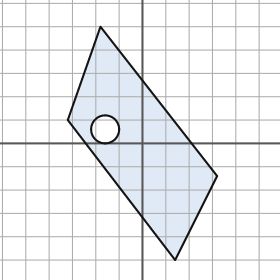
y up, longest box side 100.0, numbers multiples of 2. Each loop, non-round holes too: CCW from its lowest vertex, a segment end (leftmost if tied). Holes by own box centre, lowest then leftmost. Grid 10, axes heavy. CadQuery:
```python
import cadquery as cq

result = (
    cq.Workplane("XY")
    .moveTo(14.0, -50.0)
    .lineTo(32.0, -14.0)
    .lineTo(-18.0, 50.0)
    .lineTo(-32.0, 10.0)
    .close()
    .moveTo(-16.0, 6.0)
    .circle(6.0)
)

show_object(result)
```